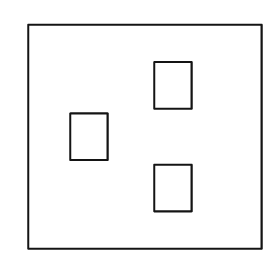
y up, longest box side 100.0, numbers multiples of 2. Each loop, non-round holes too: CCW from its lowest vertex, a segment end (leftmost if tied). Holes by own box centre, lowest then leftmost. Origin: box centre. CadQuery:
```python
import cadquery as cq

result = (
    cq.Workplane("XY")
    .moveTo(-50.0, -48.0)
    .lineTo(50.0, -48.0)
    .lineTo(50.0, 48.0)
    .lineTo(-50.0, 48.0)
    .close()
    .moveTo(4.0, -32.0)
    .lineTo(20.0, -32.0)
    .lineTo(20.0, -12.0)
    .lineTo(4.0, -12.0)
    .close()
    .moveTo(-32.0, -10.0)
    .lineTo(-16.0, -10.0)
    .lineTo(-16.0, 10.0)
    .lineTo(-32.0, 10.0)
    .close()
    .moveTo(4.0, 12.0)
    .lineTo(20.0, 12.0)
    .lineTo(20.0, 32.0)
    .lineTo(4.0, 32.0)
    .close()
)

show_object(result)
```